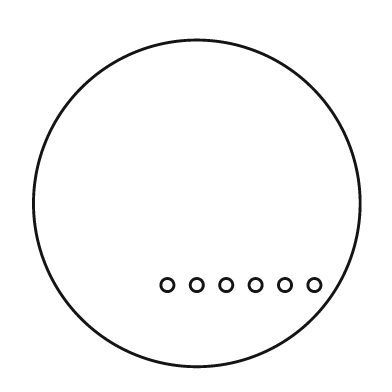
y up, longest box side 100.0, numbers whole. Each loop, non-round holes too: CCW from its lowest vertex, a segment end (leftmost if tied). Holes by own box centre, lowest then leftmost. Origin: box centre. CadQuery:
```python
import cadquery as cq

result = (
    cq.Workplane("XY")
    .moveTo(0.0, 0.0)
    .circle(50.0)
    .moveTo(-9.0, -25.0)
    .circle(2.0)
    .moveTo(0.0, -25.0)
    .circle(2.0)
    .moveTo(9.0, -25.0)
    .circle(2.0)
    .moveTo(18.0, -25.0)
    .circle(2.0)
    .moveTo(27.0, -25.0)
    .circle(2.0)
    .moveTo(36.0, -25.0)
    .circle(2.0)
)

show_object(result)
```